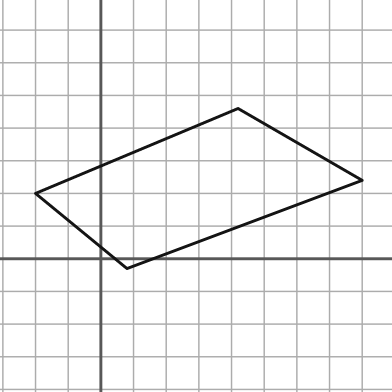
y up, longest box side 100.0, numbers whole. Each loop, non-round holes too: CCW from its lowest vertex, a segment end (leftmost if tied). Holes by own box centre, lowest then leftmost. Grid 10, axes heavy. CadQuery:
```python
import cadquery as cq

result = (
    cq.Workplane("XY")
    .moveTo(8.0, -3.0)
    .lineTo(80.0, 24.0)
    .lineTo(42.0, 46.0)
    .lineTo(-20.0, 20.0)
    .close()
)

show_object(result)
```